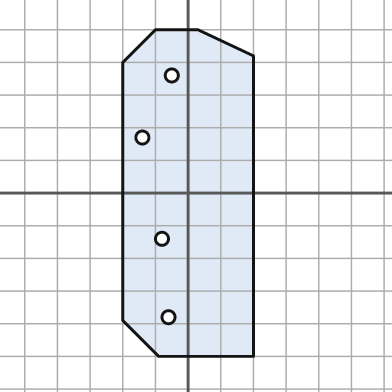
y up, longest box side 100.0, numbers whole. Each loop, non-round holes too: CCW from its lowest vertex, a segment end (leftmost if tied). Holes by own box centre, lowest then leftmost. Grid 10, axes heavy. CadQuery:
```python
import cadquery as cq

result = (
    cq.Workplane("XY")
    .moveTo(-9.0, -50.0)
    .lineTo(20.0, -50.0)
    .lineTo(20.0, 42.0)
    .lineTo(3.0, 50.0)
    .lineTo(-10.0, 50.0)
    .lineTo(-20.0, 40.0)
    .lineTo(-20.0, -39.0)
    .close()
    .moveTo(-6.0, -38.0)
    .circle(2.0)
    .moveTo(-8.0, -14.0)
    .circle(2.0)
    .moveTo(-14.0, 17.0)
    .circle(2.0)
    .moveTo(-5.0, 36.0)
    .circle(2.0)
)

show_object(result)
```